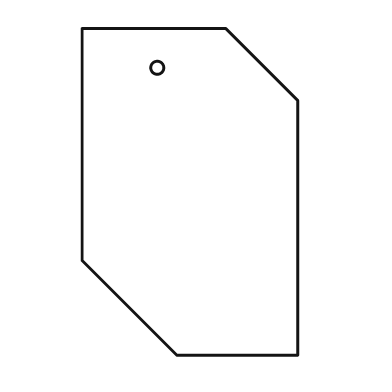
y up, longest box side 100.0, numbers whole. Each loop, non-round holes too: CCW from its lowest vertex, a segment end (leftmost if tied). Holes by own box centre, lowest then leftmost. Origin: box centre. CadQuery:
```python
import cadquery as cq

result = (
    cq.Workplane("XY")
    .moveTo(-4.0, -50.0)
    .lineTo(33.0, -50.0)
    .lineTo(33.0, 28.0)
    .lineTo(11.0, 50.0)
    .lineTo(-33.0, 50.0)
    .lineTo(-33.0, -21.0)
    .close()
    .moveTo(-10.0, 38.0)
    .circle(2.0)
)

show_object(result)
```